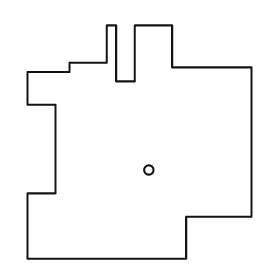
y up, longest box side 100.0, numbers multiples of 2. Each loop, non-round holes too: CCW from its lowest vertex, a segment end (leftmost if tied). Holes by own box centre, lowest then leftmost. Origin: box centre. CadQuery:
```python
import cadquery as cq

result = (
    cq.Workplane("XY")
    .moveTo(-48.0, -50.0)
    .lineTo(20.0, -50.0)
    .lineTo(20.0, -32.0)
    .lineTo(48.0, -32.0)
    .lineTo(48.0, 32.0)
    .lineTo(14.0, 32.0)
    .lineTo(14.0, 50.0)
    .lineTo(-2.0, 50.0)
    .lineTo(-2.0, 26.0)
    .lineTo(-10.0, 26.0)
    .lineTo(-10.0, 50.0)
    .lineTo(-14.0, 50.0)
    .lineTo(-14.0, 34.0)
    .lineTo(-30.0, 34.0)
    .lineTo(-30.0, 30.0)
    .lineTo(-48.0, 30.0)
    .lineTo(-48.0, 16.0)
    .lineTo(-36.0, 16.0)
    .lineTo(-36.0, -22.0)
    .lineTo(-48.0, -22.0)
    .close()
    .moveTo(4.0, -12.0)
    .circle(2.0)
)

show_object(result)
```